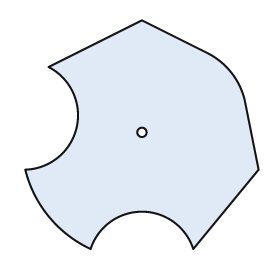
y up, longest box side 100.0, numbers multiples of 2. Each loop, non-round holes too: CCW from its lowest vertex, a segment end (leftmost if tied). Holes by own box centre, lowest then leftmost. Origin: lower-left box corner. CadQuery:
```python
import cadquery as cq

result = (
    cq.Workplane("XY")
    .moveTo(28.0, 0.0)
    .threePointArc((50.0, 16.0), (72.0, 0.0))
    .lineTo(100.0, 34.0)
    .lineTo(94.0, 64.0)
    .threePointArc((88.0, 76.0), (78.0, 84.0))
    .lineTo(50.0, 98.0)
    .lineTo(10.0, 78.0)
    .threePointArc((22.0, 52.0), (0.0, 34.0))
    .threePointArc((10.0, 14.0), (28.0, 0.0))
    .close()
    .moveTo(50.0, 50.0)
    .circle(2.0)
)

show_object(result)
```